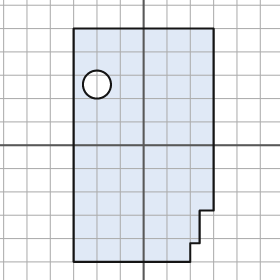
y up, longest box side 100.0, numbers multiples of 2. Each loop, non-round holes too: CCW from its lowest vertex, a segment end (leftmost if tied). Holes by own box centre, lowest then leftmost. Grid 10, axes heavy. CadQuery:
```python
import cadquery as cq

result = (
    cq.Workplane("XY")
    .moveTo(-30.0, -50.0)
    .lineTo(20.0, -50.0)
    .lineTo(20.0, -42.0)
    .lineTo(24.0, -42.0)
    .lineTo(24.0, -28.0)
    .lineTo(30.0, -28.0)
    .lineTo(30.0, 50.0)
    .lineTo(-30.0, 50.0)
    .close()
    .moveTo(-20.0, 26.0)
    .circle(6.0)
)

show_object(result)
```